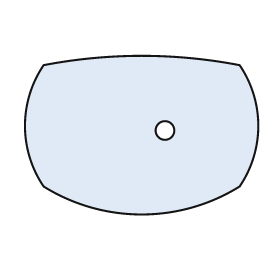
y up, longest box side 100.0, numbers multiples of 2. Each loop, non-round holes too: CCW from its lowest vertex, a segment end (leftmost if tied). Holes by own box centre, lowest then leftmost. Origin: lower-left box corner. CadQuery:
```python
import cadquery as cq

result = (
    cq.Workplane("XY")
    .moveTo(8.0, 12.0)
    .threePointArc((50.0, 0.0), (92.0, 12.0))
    .threePointArc((100.0, 38.0), (92.0, 64.0))
    .threePointArc((50.0, 68.0), (8.0, 64.0))
    .threePointArc((0.0, 38.0), (8.0, 12.0))
    .close()
    .moveTo(60.0, 36.0)
    .circle(4.0)
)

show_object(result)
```